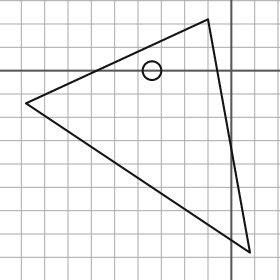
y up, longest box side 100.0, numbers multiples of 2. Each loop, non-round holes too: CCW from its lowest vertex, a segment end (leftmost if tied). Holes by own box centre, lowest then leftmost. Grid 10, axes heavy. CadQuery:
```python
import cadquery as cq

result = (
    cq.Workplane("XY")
    .moveTo(8.0, -78.0)
    .lineTo(-10.0, 22.0)
    .lineTo(-88.0, -14.0)
    .close()
    .moveTo(-34.0, 0.0)
    .circle(4.0)
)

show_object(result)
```